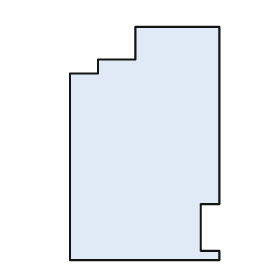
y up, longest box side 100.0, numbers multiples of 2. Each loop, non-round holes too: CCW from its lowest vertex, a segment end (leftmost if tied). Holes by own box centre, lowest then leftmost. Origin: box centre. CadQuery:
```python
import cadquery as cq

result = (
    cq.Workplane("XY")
    .moveTo(-32.0, -50.0)
    .lineTo(32.0, -50.0)
    .lineTo(32.0, -46.0)
    .lineTo(24.0, -46.0)
    .lineTo(24.0, -26.0)
    .lineTo(32.0, -26.0)
    .lineTo(32.0, 50.0)
    .lineTo(-4.0, 50.0)
    .lineTo(-4.0, 36.0)
    .lineTo(-20.0, 36.0)
    .lineTo(-20.0, 30.0)
    .lineTo(-32.0, 30.0)
    .close()
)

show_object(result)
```